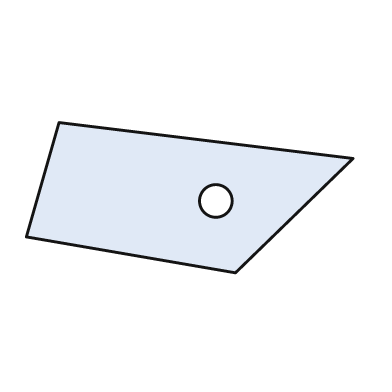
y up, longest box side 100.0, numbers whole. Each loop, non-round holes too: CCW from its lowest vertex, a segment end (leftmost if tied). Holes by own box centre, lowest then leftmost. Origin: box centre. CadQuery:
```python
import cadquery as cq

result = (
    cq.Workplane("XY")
    .moveTo(14.0, -23.0)
    .lineTo(50.0, 12.0)
    .lineTo(-40.0, 23.0)
    .lineTo(-50.0, -12.0)
    .close()
    .moveTo(8.0, -1.0)
    .circle(5.0)
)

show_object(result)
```